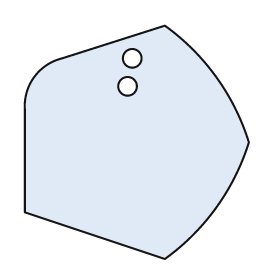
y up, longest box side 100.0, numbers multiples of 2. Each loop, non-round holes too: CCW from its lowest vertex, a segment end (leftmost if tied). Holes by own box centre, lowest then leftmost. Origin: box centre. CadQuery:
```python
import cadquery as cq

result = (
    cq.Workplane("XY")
    .moveTo(12.0, -50.0)
    .threePointArc((34.0, -28.0), (48.0, 0.0))
    .threePointArc((34.0, 28.0), (12.0, 50.0))
    .lineTo(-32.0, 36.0)
    .threePointArc((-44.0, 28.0), (-48.0, 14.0))
    .lineTo(-48.0, -30.0)
    .close()
    .moveTo(-4.0, 24.0)
    .circle(4.0)
    .moveTo(-2.0, 36.0)
    .circle(4.0)
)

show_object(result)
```